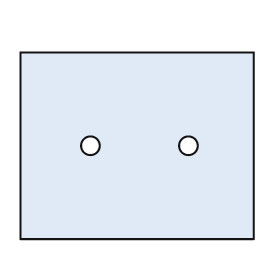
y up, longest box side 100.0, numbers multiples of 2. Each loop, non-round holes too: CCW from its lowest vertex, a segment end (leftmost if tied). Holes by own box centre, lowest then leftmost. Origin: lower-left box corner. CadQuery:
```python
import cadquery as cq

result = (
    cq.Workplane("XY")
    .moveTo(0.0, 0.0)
    .lineTo(100.0, 0.0)
    .lineTo(100.0, 80.0)
    .lineTo(0.0, 80.0)
    .close()
    .moveTo(30.0, 40.0)
    .circle(4.0)
    .moveTo(72.0, 40.0)
    .circle(4.0)
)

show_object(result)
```